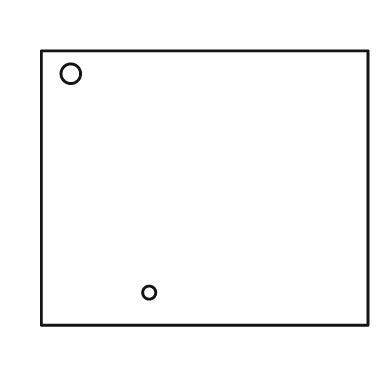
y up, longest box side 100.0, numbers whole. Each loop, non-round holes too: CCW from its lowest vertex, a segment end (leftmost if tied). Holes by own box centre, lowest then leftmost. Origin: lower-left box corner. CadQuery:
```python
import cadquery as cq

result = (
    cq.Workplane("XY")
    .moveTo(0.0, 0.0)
    .lineTo(100.0, 0.0)
    .lineTo(100.0, 84.0)
    .lineTo(0.0, 84.0)
    .close()
    .moveTo(33.0, 10.0)
    .circle(2.0)
    .moveTo(9.0, 77.0)
    .circle(3.0)
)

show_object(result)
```